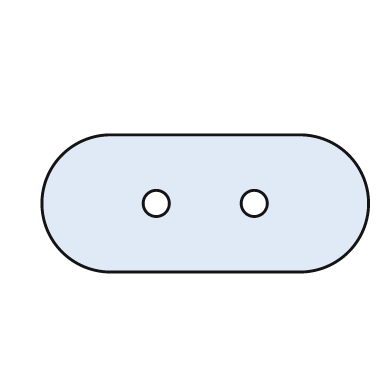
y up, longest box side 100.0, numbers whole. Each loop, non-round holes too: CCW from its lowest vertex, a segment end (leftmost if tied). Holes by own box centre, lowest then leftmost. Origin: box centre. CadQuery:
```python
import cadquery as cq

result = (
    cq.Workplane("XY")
    .moveTo(-29.0, -21.0)
    .lineTo(29.0, -21.0)
    .threePointArc((50.0, 0.0), (29.0, 21.0))
    .lineTo(-29.0, 21.0)
    .threePointArc((-50.0, 0.0), (-29.0, -21.0))
    .close()
    .moveTo(-15.0, 0.0)
    .circle(4.0)
    .moveTo(15.0, 0.0)
    .circle(4.0)
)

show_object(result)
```